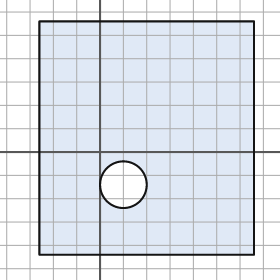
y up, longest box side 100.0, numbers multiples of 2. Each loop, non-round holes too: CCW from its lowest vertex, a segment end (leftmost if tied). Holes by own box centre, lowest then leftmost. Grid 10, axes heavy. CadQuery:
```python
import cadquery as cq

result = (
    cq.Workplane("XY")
    .moveTo(-26.0, -44.0)
    .lineTo(66.0, -44.0)
    .lineTo(66.0, 56.0)
    .lineTo(-26.0, 56.0)
    .close()
    .moveTo(10.0, -14.0)
    .circle(10.0)
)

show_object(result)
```